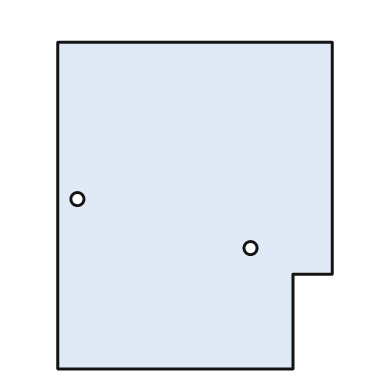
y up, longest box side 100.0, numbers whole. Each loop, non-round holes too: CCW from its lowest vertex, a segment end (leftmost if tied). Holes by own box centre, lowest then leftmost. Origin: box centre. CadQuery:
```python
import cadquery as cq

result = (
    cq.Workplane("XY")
    .moveTo(-42.0, -50.0)
    .lineTo(30.0, -50.0)
    .lineTo(30.0, -21.0)
    .lineTo(42.0, -21.0)
    .lineTo(42.0, 50.0)
    .lineTo(-42.0, 50.0)
    .close()
    .moveTo(17.0, -13.0)
    .circle(2.0)
    .moveTo(-36.0, 2.0)
    .circle(2.0)
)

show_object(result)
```